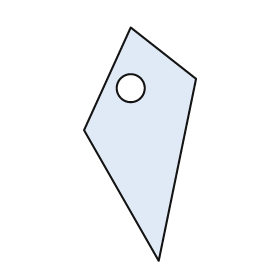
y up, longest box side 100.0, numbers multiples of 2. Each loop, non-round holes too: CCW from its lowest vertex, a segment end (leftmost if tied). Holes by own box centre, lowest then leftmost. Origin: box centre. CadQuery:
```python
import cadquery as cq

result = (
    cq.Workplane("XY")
    .moveTo(8.0, -50.0)
    .lineTo(24.0, 28.0)
    .lineTo(-4.0, 50.0)
    .lineTo(-24.0, 6.0)
    .close()
    .moveTo(-4.0, 24.0)
    .circle(6.0)
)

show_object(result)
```